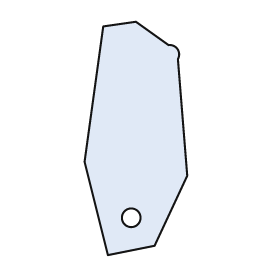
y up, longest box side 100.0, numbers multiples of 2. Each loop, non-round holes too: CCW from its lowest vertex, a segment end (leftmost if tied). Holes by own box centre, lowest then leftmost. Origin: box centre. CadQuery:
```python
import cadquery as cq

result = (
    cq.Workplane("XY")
    .moveTo(-12.0, -50.0)
    .lineTo(8.0, -46.0)
    .lineTo(22.0, -16.0)
    .lineTo(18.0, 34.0)
    .threePointArc((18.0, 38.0), (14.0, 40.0))
    .lineTo(0.0, 50.0)
    .lineTo(-14.0, 48.0)
    .lineTo(-22.0, -10.0)
    .close()
    .moveTo(-2.0, -34.0)
    .circle(4.0)
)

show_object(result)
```